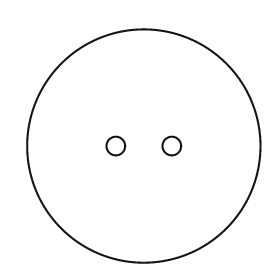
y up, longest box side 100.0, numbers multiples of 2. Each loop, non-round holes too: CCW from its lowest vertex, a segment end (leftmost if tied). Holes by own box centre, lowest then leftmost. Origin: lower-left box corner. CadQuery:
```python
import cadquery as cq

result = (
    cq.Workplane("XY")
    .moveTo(50.0, 50.0)
    .circle(50.0)
    .moveTo(38.0, 50.0)
    .circle(4.0)
    .moveTo(62.0, 50.0)
    .circle(4.0)
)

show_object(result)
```